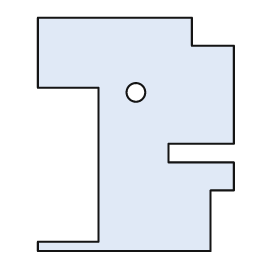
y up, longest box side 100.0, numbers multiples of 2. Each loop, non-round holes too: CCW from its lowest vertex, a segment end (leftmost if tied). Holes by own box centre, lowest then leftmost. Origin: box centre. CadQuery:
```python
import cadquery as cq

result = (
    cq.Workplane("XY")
    .moveTo(-42.0, -50.0)
    .lineTo(32.0, -50.0)
    .lineTo(32.0, -24.0)
    .lineTo(42.0, -24.0)
    .lineTo(42.0, -12.0)
    .lineTo(14.0, -12.0)
    .lineTo(14.0, -4.0)
    .lineTo(42.0, -4.0)
    .lineTo(42.0, 38.0)
    .lineTo(24.0, 38.0)
    .lineTo(24.0, 50.0)
    .lineTo(-42.0, 50.0)
    .lineTo(-42.0, 20.0)
    .lineTo(-16.0, 20.0)
    .lineTo(-16.0, -46.0)
    .lineTo(-42.0, -46.0)
    .close()
    .moveTo(0.0, 18.0)
    .circle(4.0)
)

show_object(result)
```